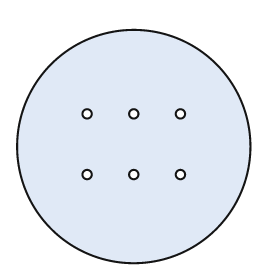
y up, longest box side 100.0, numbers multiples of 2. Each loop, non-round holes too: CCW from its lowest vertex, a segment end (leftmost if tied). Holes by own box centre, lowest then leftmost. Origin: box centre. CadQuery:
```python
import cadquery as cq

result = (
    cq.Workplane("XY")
    .moveTo(0.0, 0.0)
    .circle(50.0)
    .moveTo(-20.0, -12.0)
    .circle(2.0)
    .moveTo(0.0, -12.0)
    .circle(2.0)
    .moveTo(20.0, -12.0)
    .circle(2.0)
    .moveTo(-20.0, 14.0)
    .circle(2.0)
    .moveTo(0.0, 14.0)
    .circle(2.0)
    .moveTo(20.0, 14.0)
    .circle(2.0)
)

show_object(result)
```